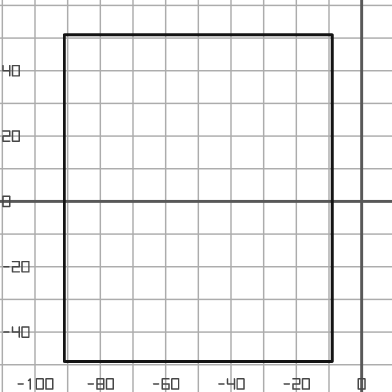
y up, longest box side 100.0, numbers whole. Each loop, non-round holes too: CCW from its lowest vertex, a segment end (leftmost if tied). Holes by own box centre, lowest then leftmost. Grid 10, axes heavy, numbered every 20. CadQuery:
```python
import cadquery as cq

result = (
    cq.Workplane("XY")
    .moveTo(-91.0, -49.0)
    .lineTo(-9.0, -49.0)
    .lineTo(-9.0, 51.0)
    .lineTo(-91.0, 51.0)
    .close()
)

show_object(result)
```